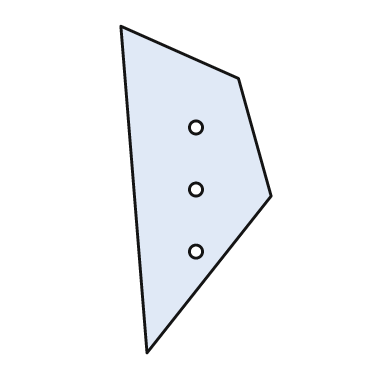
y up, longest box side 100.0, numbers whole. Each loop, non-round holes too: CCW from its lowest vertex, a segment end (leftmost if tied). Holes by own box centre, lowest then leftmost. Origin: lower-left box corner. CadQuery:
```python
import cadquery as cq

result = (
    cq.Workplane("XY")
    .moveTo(8.0, 0.0)
    .lineTo(46.0, 48.0)
    .lineTo(36.0, 84.0)
    .lineTo(0.0, 100.0)
    .close()
    .moveTo(23.0, 31.0)
    .circle(2.0)
    .moveTo(23.0, 50.0)
    .circle(2.0)
    .moveTo(23.0, 69.0)
    .circle(2.0)
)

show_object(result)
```